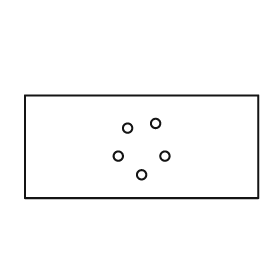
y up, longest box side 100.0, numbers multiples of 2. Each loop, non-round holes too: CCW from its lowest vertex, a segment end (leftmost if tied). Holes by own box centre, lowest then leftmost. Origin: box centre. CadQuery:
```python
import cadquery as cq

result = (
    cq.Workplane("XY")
    .moveTo(-50.0, -22.0)
    .lineTo(50.0, -22.0)
    .lineTo(50.0, 22.0)
    .lineTo(-50.0, 22.0)
    .close()
    .moveTo(0.0, -12.0)
    .circle(2.0)
    .moveTo(-10.0, -4.0)
    .circle(2.0)
    .moveTo(10.0, -4.0)
    .circle(2.0)
    .moveTo(-6.0, 8.0)
    .circle(2.0)
    .moveTo(6.0, 10.0)
    .circle(2.0)
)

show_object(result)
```